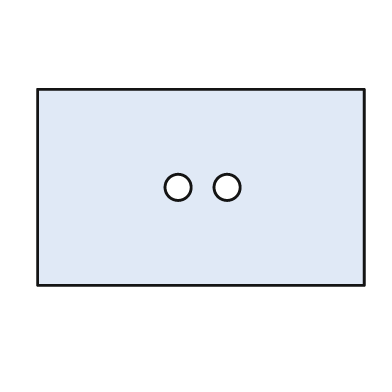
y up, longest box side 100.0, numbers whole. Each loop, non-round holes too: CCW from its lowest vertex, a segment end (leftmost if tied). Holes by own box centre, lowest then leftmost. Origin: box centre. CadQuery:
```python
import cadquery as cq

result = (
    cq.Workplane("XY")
    .moveTo(-50.0, -30.0)
    .lineTo(50.0, -30.0)
    .lineTo(50.0, 30.0)
    .lineTo(-50.0, 30.0)
    .close()
    .moveTo(-7.0, 0.0)
    .circle(4.0)
    .moveTo(8.0, 0.0)
    .circle(4.0)
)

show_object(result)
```